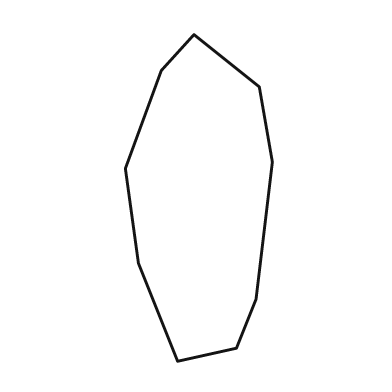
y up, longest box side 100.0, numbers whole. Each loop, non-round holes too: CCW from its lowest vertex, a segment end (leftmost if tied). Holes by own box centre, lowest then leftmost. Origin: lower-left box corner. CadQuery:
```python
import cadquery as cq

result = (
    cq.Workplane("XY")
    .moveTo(16.0, 0.0)
    .lineTo(34.0, 4.0)
    .lineTo(40.0, 19.0)
    .lineTo(45.0, 61.0)
    .lineTo(41.0, 84.0)
    .lineTo(21.0, 100.0)
    .lineTo(11.0, 89.0)
    .lineTo(0.0, 59.0)
    .lineTo(4.0, 30.0)
    .close()
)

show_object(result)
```